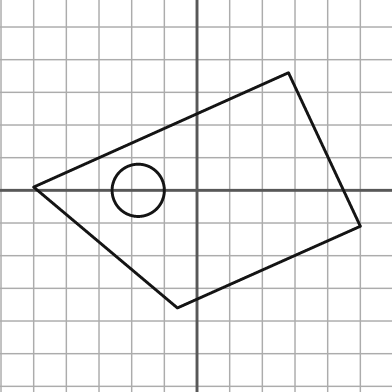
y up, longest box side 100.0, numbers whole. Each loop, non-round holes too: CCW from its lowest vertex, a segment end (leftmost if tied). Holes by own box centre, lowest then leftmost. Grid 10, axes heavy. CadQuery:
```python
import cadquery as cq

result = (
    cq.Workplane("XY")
    .moveTo(-6.0, -36.0)
    .lineTo(50.0, -11.0)
    .lineTo(28.0, 36.0)
    .lineTo(-50.0, 1.0)
    .close()
    .moveTo(-18.0, 0.0)
    .circle(8.0)
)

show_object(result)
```